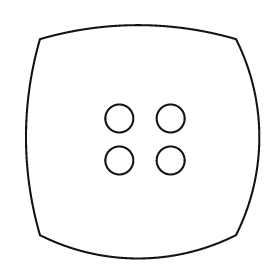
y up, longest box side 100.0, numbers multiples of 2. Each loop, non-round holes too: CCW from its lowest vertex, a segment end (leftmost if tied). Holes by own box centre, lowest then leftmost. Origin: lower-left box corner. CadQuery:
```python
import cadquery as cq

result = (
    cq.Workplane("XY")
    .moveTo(6.0, 10.0)
    .threePointArc((48.0, 0.0), (90.0, 10.0))
    .threePointArc((100.0, 52.0), (90.0, 94.0))
    .threePointArc((48.0, 100.0), (6.0, 94.0))
    .threePointArc((0.0, 52.0), (6.0, 10.0))
    .close()
    .moveTo(40.0, 42.0)
    .circle(6.0)
    .moveTo(62.0, 42.0)
    .circle(6.0)
    .moveTo(40.0, 60.0)
    .circle(6.0)
    .moveTo(62.0, 60.0)
    .circle(6.0)
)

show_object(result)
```